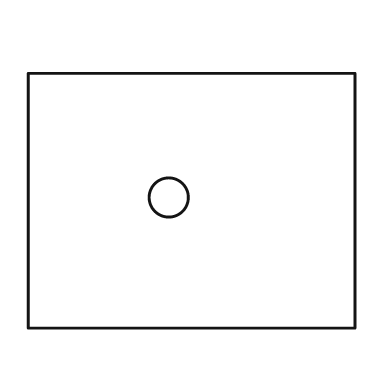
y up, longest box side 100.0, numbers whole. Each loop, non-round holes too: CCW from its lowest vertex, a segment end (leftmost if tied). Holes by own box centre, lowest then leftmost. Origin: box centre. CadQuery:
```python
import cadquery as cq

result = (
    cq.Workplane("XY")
    .moveTo(-50.0, -39.0)
    .lineTo(50.0, -39.0)
    .lineTo(50.0, 39.0)
    .lineTo(-50.0, 39.0)
    .close()
    .moveTo(-7.0, 1.0)
    .circle(6.0)
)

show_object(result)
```